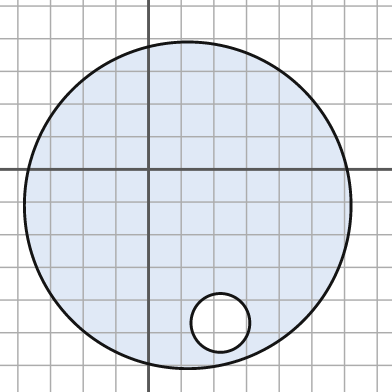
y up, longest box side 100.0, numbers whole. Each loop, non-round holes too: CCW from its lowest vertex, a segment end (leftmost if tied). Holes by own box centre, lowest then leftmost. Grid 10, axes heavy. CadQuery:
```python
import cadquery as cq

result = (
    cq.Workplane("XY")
    .moveTo(12.0, -11.0)
    .circle(50.0)
    .moveTo(22.0, -47.0)
    .circle(9.0)
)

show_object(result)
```